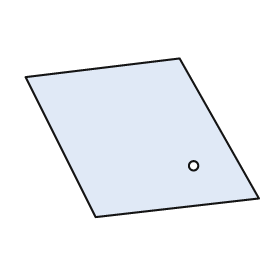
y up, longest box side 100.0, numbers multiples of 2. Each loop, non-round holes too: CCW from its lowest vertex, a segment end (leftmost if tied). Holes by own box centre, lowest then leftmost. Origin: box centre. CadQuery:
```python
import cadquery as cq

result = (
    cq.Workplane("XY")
    .moveTo(-20.0, -34.0)
    .lineTo(50.0, -26.0)
    .lineTo(16.0, 34.0)
    .lineTo(-50.0, 26.0)
    .close()
    .moveTo(22.0, -12.0)
    .circle(2.0)
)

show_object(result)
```